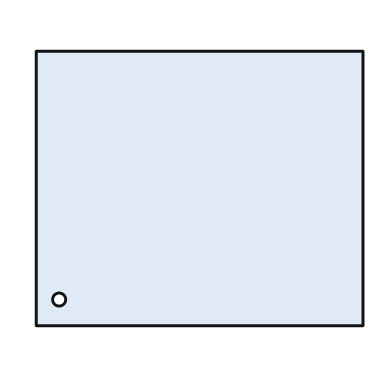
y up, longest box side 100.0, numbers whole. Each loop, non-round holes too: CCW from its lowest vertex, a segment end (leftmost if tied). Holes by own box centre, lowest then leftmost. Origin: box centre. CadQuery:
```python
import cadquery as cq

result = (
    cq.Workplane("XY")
    .moveTo(-50.0, -42.0)
    .lineTo(50.0, -42.0)
    .lineTo(50.0, 42.0)
    .lineTo(-50.0, 42.0)
    .close()
    .moveTo(-43.0, -34.0)
    .circle(2.0)
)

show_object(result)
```